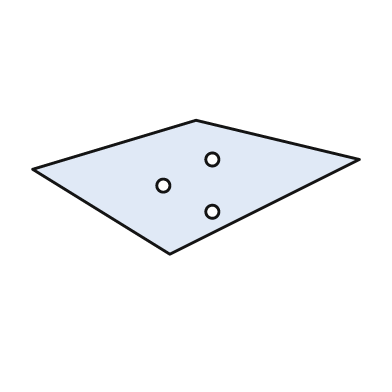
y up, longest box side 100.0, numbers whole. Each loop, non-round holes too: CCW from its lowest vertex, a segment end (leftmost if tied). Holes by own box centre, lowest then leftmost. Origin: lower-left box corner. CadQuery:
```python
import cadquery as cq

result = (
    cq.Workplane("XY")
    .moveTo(42.0, 0.0)
    .lineTo(100.0, 29.0)
    .lineTo(50.0, 41.0)
    .lineTo(0.0, 26.0)
    .close()
    .moveTo(55.0, 13.0)
    .circle(2.0)
    .moveTo(40.0, 21.0)
    .circle(2.0)
    .moveTo(55.0, 29.0)
    .circle(2.0)
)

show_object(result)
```